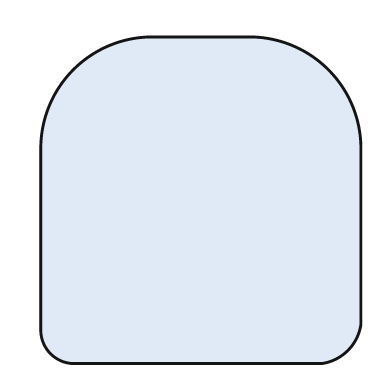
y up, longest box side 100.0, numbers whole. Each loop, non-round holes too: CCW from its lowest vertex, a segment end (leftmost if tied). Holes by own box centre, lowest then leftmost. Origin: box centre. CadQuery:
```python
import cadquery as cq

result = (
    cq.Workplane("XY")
    .moveTo(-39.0, -50.0)
    .lineTo(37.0, -50.0)
    .threePointArc((45.0, -46.0), (49.0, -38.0))
    .lineTo(49.0, 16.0)
    .threePointArc((39.0, 40.0), (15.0, 50.0))
    .lineTo(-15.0, 50.0)
    .threePointArc((-39.0, 40.0), (-49.0, 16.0))
    .lineTo(-49.0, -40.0)
    .threePointArc((-46.0, -47.0), (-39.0, -50.0))
    .close()
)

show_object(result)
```